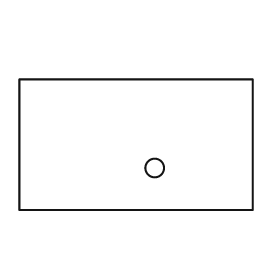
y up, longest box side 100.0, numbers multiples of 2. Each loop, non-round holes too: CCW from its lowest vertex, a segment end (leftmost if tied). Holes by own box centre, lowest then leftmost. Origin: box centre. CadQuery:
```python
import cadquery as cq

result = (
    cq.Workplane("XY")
    .moveTo(-50.0, -28.0)
    .lineTo(50.0, -28.0)
    .lineTo(50.0, 28.0)
    .lineTo(-50.0, 28.0)
    .close()
    .moveTo(8.0, -10.0)
    .circle(4.0)
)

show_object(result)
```